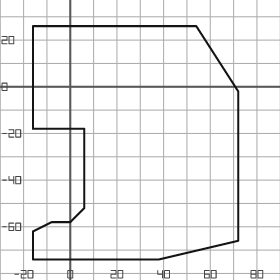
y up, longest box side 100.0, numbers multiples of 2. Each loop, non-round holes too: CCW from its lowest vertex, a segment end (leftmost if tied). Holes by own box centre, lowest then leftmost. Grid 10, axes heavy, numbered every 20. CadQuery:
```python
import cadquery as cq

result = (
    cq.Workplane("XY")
    .moveTo(-16.0, -74.0)
    .lineTo(38.0, -74.0)
    .lineTo(72.0, -66.0)
    .lineTo(72.0, -2.0)
    .lineTo(54.0, 26.0)
    .lineTo(-16.0, 26.0)
    .lineTo(-16.0, -18.0)
    .lineTo(6.0, -18.0)
    .lineTo(6.0, -52.0)
    .lineTo(0.0, -58.0)
    .lineTo(-8.0, -58.0)
    .lineTo(-16.0, -62.0)
    .close()
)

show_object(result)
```